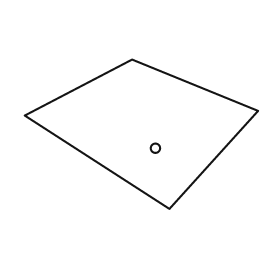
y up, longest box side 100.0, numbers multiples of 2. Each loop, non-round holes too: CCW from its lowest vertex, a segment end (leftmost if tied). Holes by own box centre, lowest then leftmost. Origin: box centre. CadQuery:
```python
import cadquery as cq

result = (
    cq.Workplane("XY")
    .moveTo(12.0, -32.0)
    .lineTo(50.0, 10.0)
    .lineTo(-4.0, 32.0)
    .lineTo(-50.0, 8.0)
    .close()
    .moveTo(6.0, -6.0)
    .circle(2.0)
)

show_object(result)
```